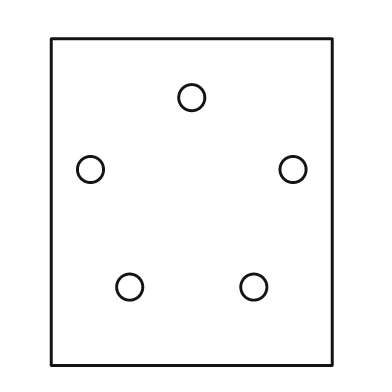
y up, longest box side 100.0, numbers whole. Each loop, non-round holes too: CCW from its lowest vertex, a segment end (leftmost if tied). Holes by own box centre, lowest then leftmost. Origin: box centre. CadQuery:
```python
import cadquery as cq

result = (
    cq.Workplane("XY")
    .moveTo(-43.0, -50.0)
    .lineTo(43.0, -50.0)
    .lineTo(43.0, 50.0)
    .lineTo(-43.0, 50.0)
    .close()
    .moveTo(-19.0, -26.0)
    .circle(4.0)
    .moveTo(19.0, -26.0)
    .circle(4.0)
    .moveTo(-31.0, 10.0)
    .circle(4.0)
    .moveTo(31.0, 10.0)
    .circle(4.0)
    .moveTo(0.0, 32.0)
    .circle(4.0)
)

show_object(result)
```